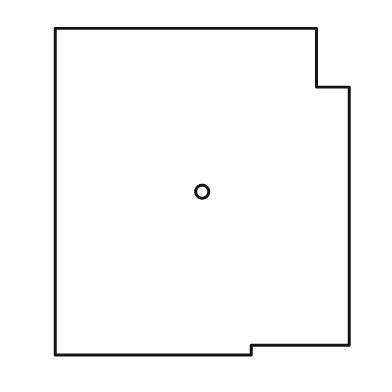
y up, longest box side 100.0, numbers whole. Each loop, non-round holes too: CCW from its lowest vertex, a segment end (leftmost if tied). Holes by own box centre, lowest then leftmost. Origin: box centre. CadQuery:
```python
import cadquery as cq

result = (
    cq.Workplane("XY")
    .moveTo(-45.0, -50.0)
    .lineTo(15.0, -50.0)
    .lineTo(15.0, -47.0)
    .lineTo(45.0, -47.0)
    .lineTo(45.0, 32.0)
    .lineTo(35.0, 32.0)
    .lineTo(35.0, 50.0)
    .lineTo(-45.0, 50.0)
    .close()
    .moveTo(0.0, 0.0)
    .circle(2.0)
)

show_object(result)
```